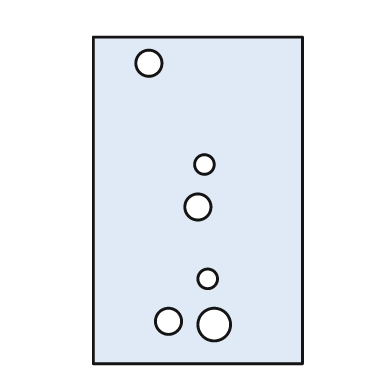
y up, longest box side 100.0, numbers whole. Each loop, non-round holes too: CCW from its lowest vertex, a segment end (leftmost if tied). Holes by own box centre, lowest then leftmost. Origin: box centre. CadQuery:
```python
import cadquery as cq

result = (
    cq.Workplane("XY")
    .moveTo(-32.0, -50.0)
    .lineTo(32.0, -50.0)
    .lineTo(32.0, 50.0)
    .lineTo(-32.0, 50.0)
    .close()
    .moveTo(5.0, -38.0)
    .circle(5.0)
    .moveTo(-9.0, -37.0)
    .circle(4.0)
    .moveTo(3.0, -24.0)
    .circle(3.0)
    .moveTo(0.0, -2.0)
    .circle(4.0)
    .moveTo(2.0, 11.0)
    .circle(3.0)
    .moveTo(-15.0, 42.0)
    .circle(4.0)
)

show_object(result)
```